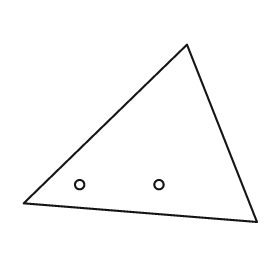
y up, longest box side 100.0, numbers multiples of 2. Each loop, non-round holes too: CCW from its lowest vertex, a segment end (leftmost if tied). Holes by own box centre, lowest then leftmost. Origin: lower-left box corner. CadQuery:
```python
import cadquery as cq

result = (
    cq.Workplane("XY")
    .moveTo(100.0, 0.0)
    .lineTo(70.0, 76.0)
    .lineTo(0.0, 8.0)
    .close()
    .moveTo(24.0, 16.0)
    .circle(2.0)
    .moveTo(58.0, 16.0)
    .circle(2.0)
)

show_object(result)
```